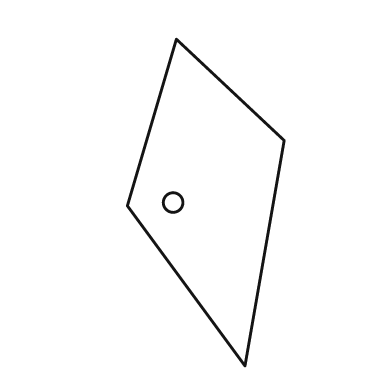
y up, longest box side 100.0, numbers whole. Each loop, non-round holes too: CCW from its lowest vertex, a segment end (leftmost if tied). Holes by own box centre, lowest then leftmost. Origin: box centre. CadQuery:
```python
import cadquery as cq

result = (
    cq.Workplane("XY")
    .moveTo(12.0, -50.0)
    .lineTo(24.0, 19.0)
    .lineTo(-9.0, 50.0)
    .lineTo(-24.0, -1.0)
    .close()
    .moveTo(-10.0, 0.0)
    .circle(3.0)
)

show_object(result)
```